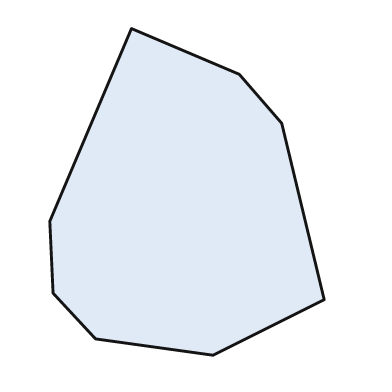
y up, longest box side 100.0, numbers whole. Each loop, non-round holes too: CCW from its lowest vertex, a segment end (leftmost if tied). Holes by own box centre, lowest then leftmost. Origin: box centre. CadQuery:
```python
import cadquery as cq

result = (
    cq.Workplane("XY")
    .moveTo(8.0, -50.0)
    .lineTo(42.0, -33.0)
    .lineTo(29.0, 21.0)
    .lineTo(16.0, 36.0)
    .lineTo(-17.0, 50.0)
    .lineTo(-42.0, -9.0)
    .lineTo(-41.0, -31.0)
    .lineTo(-28.0, -45.0)
    .close()
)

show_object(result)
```